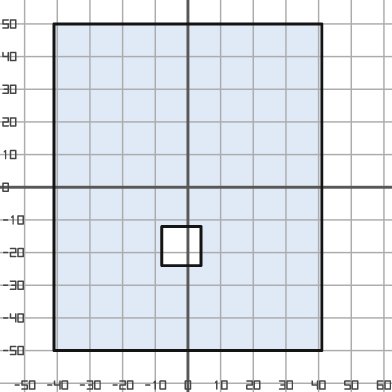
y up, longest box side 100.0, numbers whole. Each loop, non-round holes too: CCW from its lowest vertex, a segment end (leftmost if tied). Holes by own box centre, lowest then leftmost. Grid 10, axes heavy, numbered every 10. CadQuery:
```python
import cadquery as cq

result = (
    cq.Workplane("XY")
    .moveTo(-41.0, -50.0)
    .lineTo(41.0, -50.0)
    .lineTo(41.0, 50.0)
    .lineTo(-41.0, 50.0)
    .close()
    .moveTo(-8.0, -24.0)
    .lineTo(4.0, -24.0)
    .lineTo(4.0, -12.0)
    .lineTo(-8.0, -12.0)
    .close()
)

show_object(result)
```